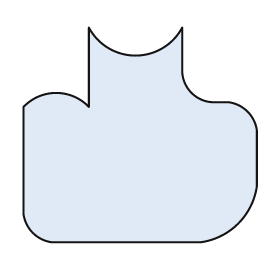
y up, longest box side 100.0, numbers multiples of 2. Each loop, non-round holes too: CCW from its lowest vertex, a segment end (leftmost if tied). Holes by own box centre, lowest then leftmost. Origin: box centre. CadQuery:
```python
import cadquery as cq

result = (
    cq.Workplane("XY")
    .moveTo(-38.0, -46.0)
    .lineTo(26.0, -46.0)
    .threePointArc((42.0, -38.0), (50.0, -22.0))
    .lineTo(50.0, 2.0)
    .threePointArc((46.0, 10.0), (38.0, 14.0))
    .lineTo(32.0, 14.0)
    .threePointArc((22.0, 18.0), (18.0, 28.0))
    .lineTo(18.0, 46.0)
    .threePointArc((-2.0, 34.0), (-22.0, 46.0))
    .lineTo(-22.0, 12.0)
    .threePointArc((-36.0, 18.0), (-50.0, 12.0))
    .lineTo(-50.0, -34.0)
    .threePointArc((-46.0, -42.0), (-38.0, -46.0))
    .close()
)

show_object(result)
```